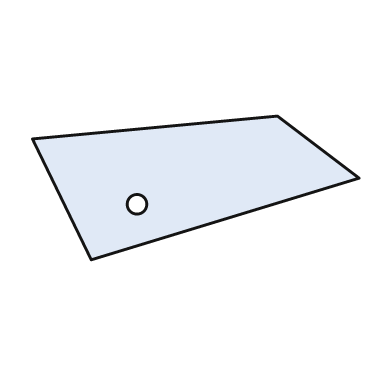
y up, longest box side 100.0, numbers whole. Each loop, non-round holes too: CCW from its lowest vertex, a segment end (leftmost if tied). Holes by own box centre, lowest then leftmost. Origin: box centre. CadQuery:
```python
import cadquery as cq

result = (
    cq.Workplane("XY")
    .moveTo(-32.0, -22.0)
    .lineTo(50.0, 3.0)
    .lineTo(25.0, 22.0)
    .lineTo(-50.0, 15.0)
    .close()
    .moveTo(-18.0, -5.0)
    .circle(3.0)
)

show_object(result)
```